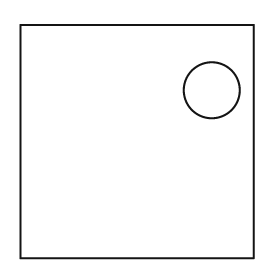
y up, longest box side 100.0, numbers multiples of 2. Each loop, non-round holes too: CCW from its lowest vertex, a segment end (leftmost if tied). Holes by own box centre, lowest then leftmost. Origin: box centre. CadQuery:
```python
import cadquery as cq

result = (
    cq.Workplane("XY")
    .moveTo(-50.0, -50.0)
    .lineTo(50.0, -50.0)
    .lineTo(50.0, 50.0)
    .lineTo(-50.0, 50.0)
    .close()
    .moveTo(32.0, 22.0)
    .circle(12.0)
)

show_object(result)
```